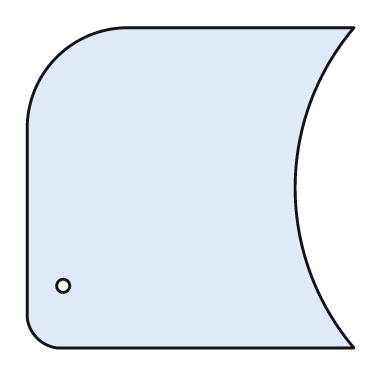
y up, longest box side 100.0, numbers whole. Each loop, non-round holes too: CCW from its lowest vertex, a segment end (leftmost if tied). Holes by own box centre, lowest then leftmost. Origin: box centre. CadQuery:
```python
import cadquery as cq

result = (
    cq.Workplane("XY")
    .moveTo(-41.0, -49.0)
    .lineTo(50.0, -49.0)
    .threePointArc((32.0, 0.0), (50.0, 49.0))
    .lineTo(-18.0, 49.0)
    .threePointArc((-41.0, 40.0), (-50.0, 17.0))
    .lineTo(-50.0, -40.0)
    .threePointArc((-47.0, -46.0), (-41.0, -49.0))
    .close()
    .moveTo(-39.0, -30.0)
    .circle(2.0)
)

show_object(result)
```